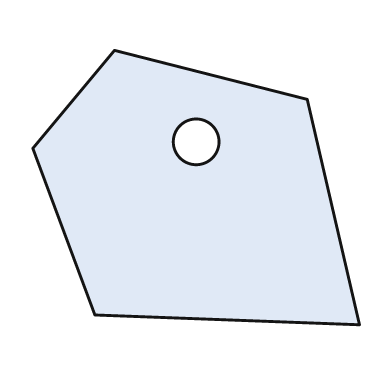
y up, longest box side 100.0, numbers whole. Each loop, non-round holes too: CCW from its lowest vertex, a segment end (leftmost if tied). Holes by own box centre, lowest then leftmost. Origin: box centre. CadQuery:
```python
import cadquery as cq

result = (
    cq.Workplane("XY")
    .moveTo(50.0, -42.0)
    .lineTo(34.0, 27.0)
    .lineTo(-25.0, 42.0)
    .lineTo(-50.0, 12.0)
    .lineTo(-31.0, -39.0)
    .close()
    .moveTo(0.0, 14.0)
    .circle(7.0)
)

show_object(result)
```